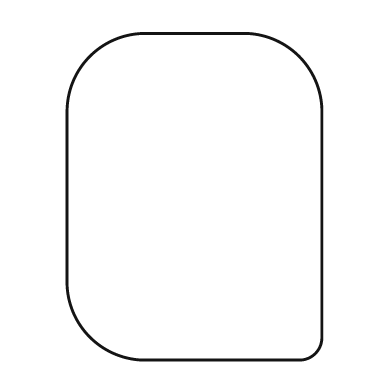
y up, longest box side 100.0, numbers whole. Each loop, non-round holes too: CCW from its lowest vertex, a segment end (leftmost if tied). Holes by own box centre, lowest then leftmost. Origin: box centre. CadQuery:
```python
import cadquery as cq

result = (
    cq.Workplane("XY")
    .moveTo(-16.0, -50.0)
    .lineTo(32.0, -50.0)
    .threePointArc((37.0, -48.0), (39.0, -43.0))
    .lineTo(39.0, 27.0)
    .threePointArc((32.0, 43.0), (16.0, 50.0))
    .lineTo(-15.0, 50.0)
    .threePointArc((-32.0, 43.0), (-39.0, 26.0))
    .lineTo(-39.0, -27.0)
    .threePointArc((-32.0, -43.0), (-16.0, -50.0))
    .close()
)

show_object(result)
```